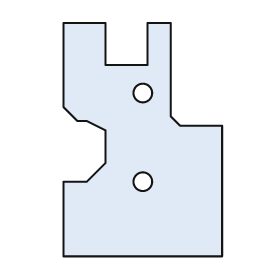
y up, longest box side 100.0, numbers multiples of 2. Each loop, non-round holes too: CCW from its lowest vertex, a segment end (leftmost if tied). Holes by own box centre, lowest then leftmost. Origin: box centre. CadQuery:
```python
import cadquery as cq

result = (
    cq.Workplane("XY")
    .moveTo(-34.0, -50.0)
    .lineTo(34.0, -50.0)
    .lineTo(34.0, 6.0)
    .lineTo(16.0, 6.0)
    .lineTo(12.0, 10.0)
    .lineTo(12.0, 50.0)
    .lineTo(2.0, 50.0)
    .lineTo(2.0, 32.0)
    .lineTo(-16.0, 32.0)
    .lineTo(-16.0, 50.0)
    .lineTo(-34.0, 50.0)
    .lineTo(-34.0, 14.0)
    .lineTo(-28.0, 8.0)
    .lineTo(-24.0, 8.0)
    .lineTo(-16.0, 4.0)
    .lineTo(-16.0, -10.0)
    .lineTo(-24.0, -18.0)
    .lineTo(-34.0, -18.0)
    .close()
    .moveTo(0.0, -18.0)
    .circle(4.0)
    .moveTo(0.0, 20.0)
    .circle(4.0)
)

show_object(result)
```